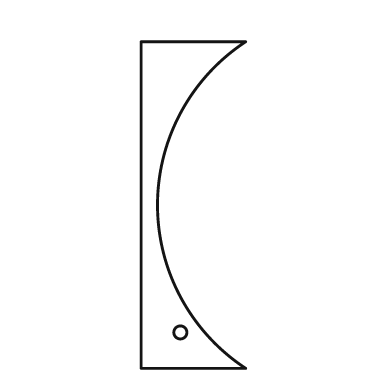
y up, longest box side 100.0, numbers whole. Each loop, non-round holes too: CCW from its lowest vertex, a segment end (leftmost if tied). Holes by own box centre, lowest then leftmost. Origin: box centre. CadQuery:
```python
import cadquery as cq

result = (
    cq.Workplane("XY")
    .moveTo(-16.0, -50.0)
    .lineTo(16.0, -50.0)
    .threePointArc((-11.0, 0.0), (16.0, 50.0))
    .lineTo(-16.0, 50.0)
    .close()
    .moveTo(-4.0, -39.0)
    .circle(2.0)
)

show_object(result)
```